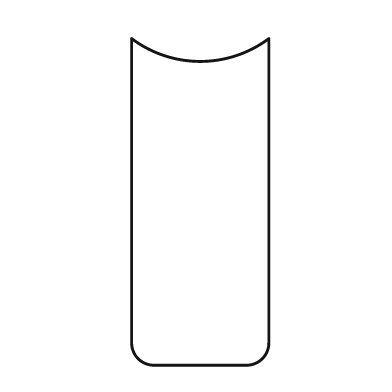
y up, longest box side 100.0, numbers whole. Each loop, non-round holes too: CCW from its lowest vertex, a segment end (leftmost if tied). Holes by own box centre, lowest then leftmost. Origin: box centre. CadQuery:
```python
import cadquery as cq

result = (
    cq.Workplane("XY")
    .moveTo(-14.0, -50.0)
    .lineTo(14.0, -50.0)
    .threePointArc((19.0, -48.0), (21.0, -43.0))
    .lineTo(21.0, 50.0)
    .threePointArc((0.0, 43.0), (-21.0, 50.0))
    .lineTo(-21.0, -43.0)
    .threePointArc((-19.0, -48.0), (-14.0, -50.0))
    .close()
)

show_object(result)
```